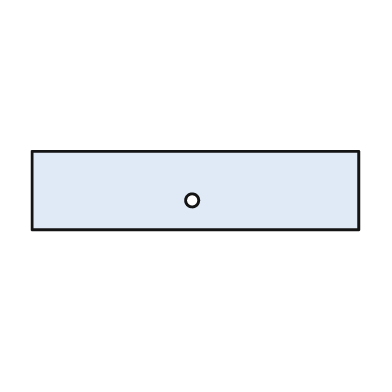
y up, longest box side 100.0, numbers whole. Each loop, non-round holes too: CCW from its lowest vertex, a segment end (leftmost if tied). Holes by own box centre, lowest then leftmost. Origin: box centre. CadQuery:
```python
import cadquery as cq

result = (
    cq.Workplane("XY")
    .moveTo(-50.0, -12.0)
    .lineTo(50.0, -12.0)
    .lineTo(50.0, 12.0)
    .lineTo(-50.0, 12.0)
    .close()
    .moveTo(-1.0, -3.0)
    .circle(2.0)
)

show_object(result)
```